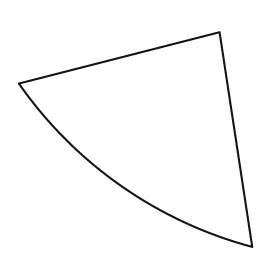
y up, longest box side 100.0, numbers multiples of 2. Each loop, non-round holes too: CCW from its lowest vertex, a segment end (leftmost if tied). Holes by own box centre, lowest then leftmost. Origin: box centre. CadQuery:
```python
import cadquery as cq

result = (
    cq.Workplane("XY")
    .moveTo(50.0, -46.0)
    .lineTo(36.0, 46.0)
    .lineTo(-50.0, 24.0)
    .threePointArc((-6.0, -20.0), (50.0, -46.0))
    .close()
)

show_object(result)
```